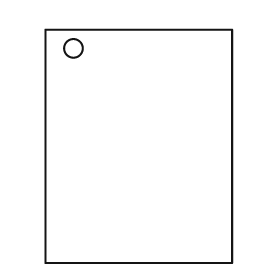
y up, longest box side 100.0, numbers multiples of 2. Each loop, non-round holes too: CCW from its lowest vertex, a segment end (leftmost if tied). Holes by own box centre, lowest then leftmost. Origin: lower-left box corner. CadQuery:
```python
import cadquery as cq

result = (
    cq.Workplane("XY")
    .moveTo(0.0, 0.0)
    .lineTo(80.0, 0.0)
    .lineTo(80.0, 100.0)
    .lineTo(0.0, 100.0)
    .close()
    .moveTo(12.0, 92.0)
    .circle(4.0)
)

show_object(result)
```